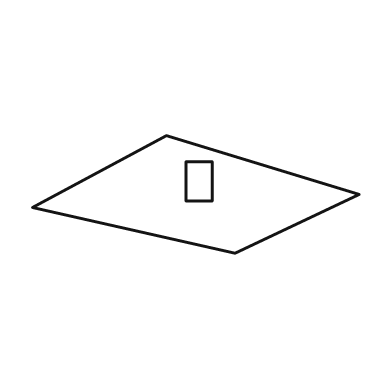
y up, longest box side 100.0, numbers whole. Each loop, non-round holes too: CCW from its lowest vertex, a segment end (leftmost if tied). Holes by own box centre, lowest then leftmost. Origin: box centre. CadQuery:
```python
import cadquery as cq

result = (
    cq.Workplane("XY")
    .moveTo(12.0, -18.0)
    .lineTo(50.0, 0.0)
    .lineTo(-9.0, 18.0)
    .lineTo(-50.0, -4.0)
    .close()
    .moveTo(-3.0, -2.0)
    .lineTo(5.0, -2.0)
    .lineTo(5.0, 10.0)
    .lineTo(-3.0, 10.0)
    .close()
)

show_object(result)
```